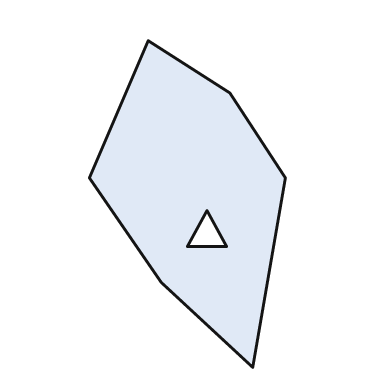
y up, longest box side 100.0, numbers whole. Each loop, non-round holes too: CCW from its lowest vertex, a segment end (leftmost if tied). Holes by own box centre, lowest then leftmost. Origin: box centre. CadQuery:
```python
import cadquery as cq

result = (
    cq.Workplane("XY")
    .moveTo(20.0, -50.0)
    .lineTo(30.0, 8.0)
    .lineTo(13.0, 34.0)
    .lineTo(-12.0, 50.0)
    .lineTo(-30.0, 8.0)
    .lineTo(-8.0, -24.0)
    .close()
    .moveTo(0.0, -13.0)
    .lineTo(12.0, -13.0)
    .lineTo(6.0, -2.0)
    .close()
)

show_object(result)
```